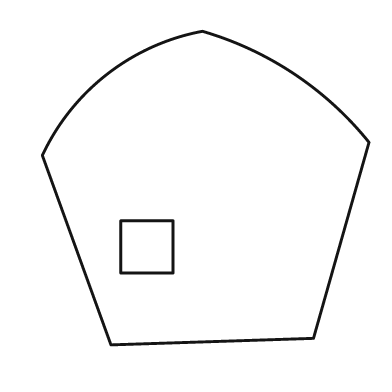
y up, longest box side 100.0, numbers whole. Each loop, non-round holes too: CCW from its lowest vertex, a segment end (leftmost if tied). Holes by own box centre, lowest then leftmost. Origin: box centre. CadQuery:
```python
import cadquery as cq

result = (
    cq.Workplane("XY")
    .moveTo(-29.0, -48.0)
    .lineTo(33.0, -46.0)
    .lineTo(50.0, 14.0)
    .threePointArc((27.0, 35.0), (-1.0, 48.0))
    .threePointArc((-30.0, 35.0), (-50.0, 10.0))
    .close()
    .moveTo(-26.0, -26.0)
    .lineTo(-10.0, -26.0)
    .lineTo(-10.0, -10.0)
    .lineTo(-26.0, -10.0)
    .close()
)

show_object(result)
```